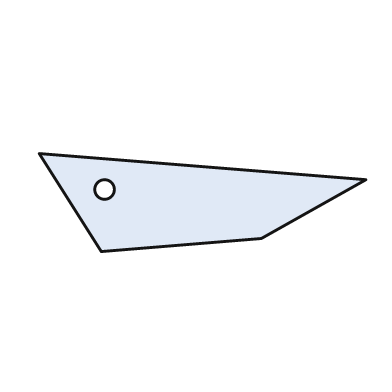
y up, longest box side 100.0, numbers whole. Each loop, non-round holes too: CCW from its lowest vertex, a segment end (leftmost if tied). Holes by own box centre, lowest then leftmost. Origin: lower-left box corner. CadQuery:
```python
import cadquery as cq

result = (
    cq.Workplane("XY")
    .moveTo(19.0, 0.0)
    .lineTo(68.0, 4.0)
    .lineTo(100.0, 22.0)
    .lineTo(0.0, 30.0)
    .close()
    .moveTo(20.0, 19.0)
    .circle(3.0)
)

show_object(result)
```